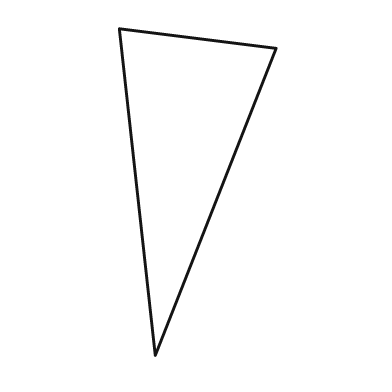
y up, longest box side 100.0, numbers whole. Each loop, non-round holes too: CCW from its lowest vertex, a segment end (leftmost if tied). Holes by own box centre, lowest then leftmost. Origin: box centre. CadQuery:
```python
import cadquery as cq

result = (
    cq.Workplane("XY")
    .moveTo(-13.0, -50.0)
    .lineTo(24.0, 44.0)
    .lineTo(-24.0, 50.0)
    .close()
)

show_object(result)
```